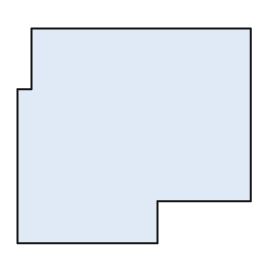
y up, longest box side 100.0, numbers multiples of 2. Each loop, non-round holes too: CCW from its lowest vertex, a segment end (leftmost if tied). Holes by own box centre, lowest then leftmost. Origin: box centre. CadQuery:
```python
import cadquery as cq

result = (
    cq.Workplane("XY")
    .moveTo(-50.0, -46.0)
    .lineTo(10.0, -46.0)
    .lineTo(10.0, -28.0)
    .lineTo(50.0, -28.0)
    .lineTo(50.0, 46.0)
    .lineTo(-44.0, 46.0)
    .lineTo(-44.0, 20.0)
    .lineTo(-50.0, 20.0)
    .close()
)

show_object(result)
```